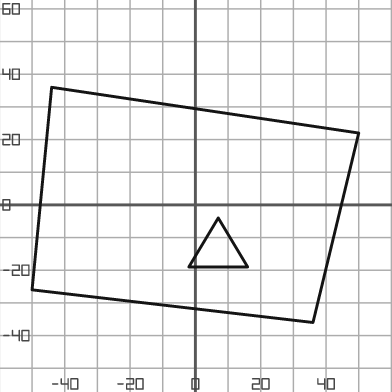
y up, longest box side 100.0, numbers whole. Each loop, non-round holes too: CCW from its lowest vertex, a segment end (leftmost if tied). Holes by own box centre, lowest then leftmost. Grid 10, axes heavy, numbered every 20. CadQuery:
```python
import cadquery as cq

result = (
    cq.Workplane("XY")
    .moveTo(36.0, -36.0)
    .lineTo(50.0, 22.0)
    .lineTo(-44.0, 36.0)
    .lineTo(-50.0, -26.0)
    .close()
    .moveTo(-2.0, -19.0)
    .lineTo(16.0, -19.0)
    .lineTo(7.0, -4.0)
    .close()
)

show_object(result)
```